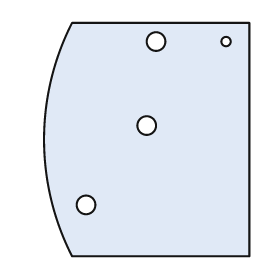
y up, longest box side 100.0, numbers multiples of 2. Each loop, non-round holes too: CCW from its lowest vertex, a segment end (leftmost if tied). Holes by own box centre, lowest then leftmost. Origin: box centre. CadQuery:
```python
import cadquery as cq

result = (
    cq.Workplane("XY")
    .moveTo(-32.0, -50.0)
    .lineTo(44.0, -50.0)
    .lineTo(44.0, 50.0)
    .lineTo(-32.0, 50.0)
    .threePointArc((-44.0, 0.0), (-32.0, -50.0))
    .close()
    .moveTo(-26.0, -28.0)
    .circle(4.0)
    .moveTo(0.0, 6.0)
    .circle(4.0)
    .moveTo(4.0, 42.0)
    .circle(4.0)
    .moveTo(34.0, 42.0)
    .circle(2.0)
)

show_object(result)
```